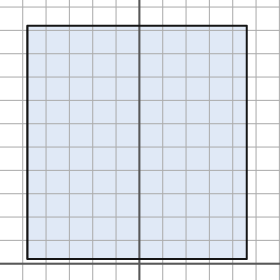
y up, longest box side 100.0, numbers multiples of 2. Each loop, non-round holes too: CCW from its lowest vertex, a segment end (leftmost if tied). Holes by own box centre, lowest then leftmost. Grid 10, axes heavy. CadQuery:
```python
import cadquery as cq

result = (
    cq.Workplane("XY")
    .moveTo(-48.0, 2.0)
    .lineTo(46.0, 2.0)
    .lineTo(46.0, 102.0)
    .lineTo(-48.0, 102.0)
    .close()
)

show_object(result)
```